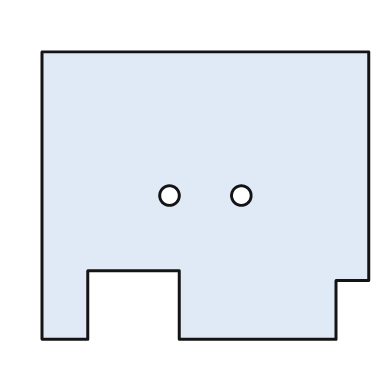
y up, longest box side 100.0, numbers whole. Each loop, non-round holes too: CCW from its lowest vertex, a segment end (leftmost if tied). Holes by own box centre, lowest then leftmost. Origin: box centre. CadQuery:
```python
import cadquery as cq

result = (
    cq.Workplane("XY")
    .moveTo(-50.0, -44.0)
    .lineTo(-36.0, -44.0)
    .lineTo(-36.0, -23.0)
    .lineTo(-8.0, -23.0)
    .lineTo(-8.0, -44.0)
    .lineTo(40.0, -44.0)
    .lineTo(40.0, -26.0)
    .lineTo(50.0, -26.0)
    .lineTo(50.0, 44.0)
    .lineTo(-50.0, 44.0)
    .close()
    .moveTo(-11.0, 0.0)
    .circle(3.0)
    .moveTo(11.0, 0.0)
    .circle(3.0)
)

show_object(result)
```